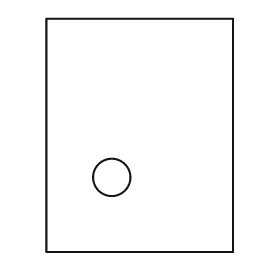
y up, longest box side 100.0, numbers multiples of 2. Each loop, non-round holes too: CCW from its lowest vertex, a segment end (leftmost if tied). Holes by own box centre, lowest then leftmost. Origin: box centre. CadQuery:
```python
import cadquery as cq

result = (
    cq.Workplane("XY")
    .moveTo(-40.0, -50.0)
    .lineTo(40.0, -50.0)
    .lineTo(40.0, 50.0)
    .lineTo(-40.0, 50.0)
    .close()
    .moveTo(-12.0, -18.0)
    .circle(8.0)
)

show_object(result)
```